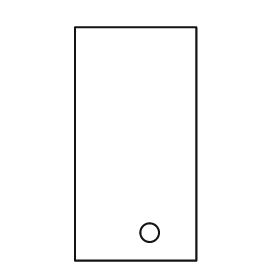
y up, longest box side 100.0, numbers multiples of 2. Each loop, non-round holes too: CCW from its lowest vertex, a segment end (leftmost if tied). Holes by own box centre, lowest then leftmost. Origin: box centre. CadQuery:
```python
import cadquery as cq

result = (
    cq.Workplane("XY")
    .moveTo(-26.0, -50.0)
    .lineTo(26.0, -50.0)
    .lineTo(26.0, 50.0)
    .lineTo(-26.0, 50.0)
    .close()
    .moveTo(6.0, -38.0)
    .circle(4.0)
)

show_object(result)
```